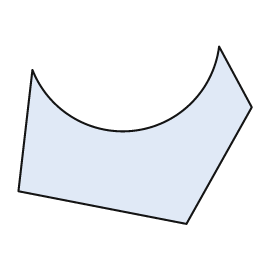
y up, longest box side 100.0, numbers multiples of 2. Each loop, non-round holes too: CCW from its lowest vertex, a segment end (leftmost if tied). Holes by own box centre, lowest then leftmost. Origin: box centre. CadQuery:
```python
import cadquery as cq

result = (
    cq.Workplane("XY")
    .moveTo(22.0, -38.0)
    .lineTo(50.0, 12.0)
    .lineTo(36.0, 38.0)
    .threePointArc((0.0, 2.0), (-44.0, 28.0))
    .lineTo(-50.0, -24.0)
    .close()
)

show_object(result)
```